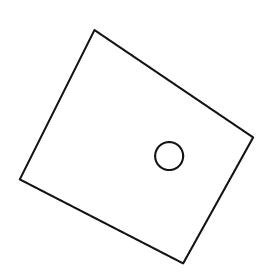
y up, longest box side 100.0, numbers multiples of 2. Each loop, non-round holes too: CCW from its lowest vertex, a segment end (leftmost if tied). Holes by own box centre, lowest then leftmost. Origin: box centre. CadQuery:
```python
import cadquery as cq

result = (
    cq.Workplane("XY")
    .moveTo(20.0, -50.0)
    .lineTo(50.0, 4.0)
    .lineTo(-18.0, 50.0)
    .lineTo(-50.0, -14.0)
    .close()
    .moveTo(14.0, -4.0)
    .circle(6.0)
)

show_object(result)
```